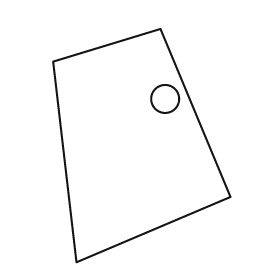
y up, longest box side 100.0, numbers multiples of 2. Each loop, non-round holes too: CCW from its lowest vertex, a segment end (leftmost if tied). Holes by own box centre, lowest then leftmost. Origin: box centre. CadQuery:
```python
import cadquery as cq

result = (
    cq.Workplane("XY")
    .moveTo(-28.0, -50.0)
    .lineTo(38.0, -22.0)
    .lineTo(8.0, 50.0)
    .lineTo(-38.0, 36.0)
    .close()
    .moveTo(10.0, 20.0)
    .circle(6.0)
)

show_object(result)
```